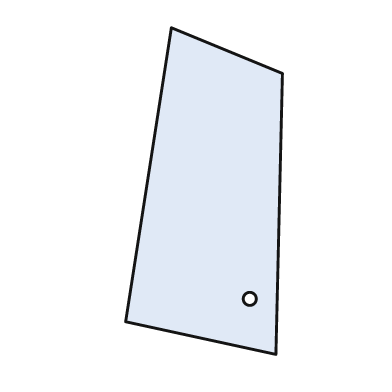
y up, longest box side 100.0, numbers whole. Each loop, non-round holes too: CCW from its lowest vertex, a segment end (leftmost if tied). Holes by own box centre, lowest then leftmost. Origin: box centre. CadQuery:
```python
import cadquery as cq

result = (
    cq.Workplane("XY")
    .moveTo(22.0, -50.0)
    .lineTo(24.0, 36.0)
    .lineTo(-10.0, 50.0)
    .lineTo(-24.0, -40.0)
    .close()
    .moveTo(14.0, -33.0)
    .circle(2.0)
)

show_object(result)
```